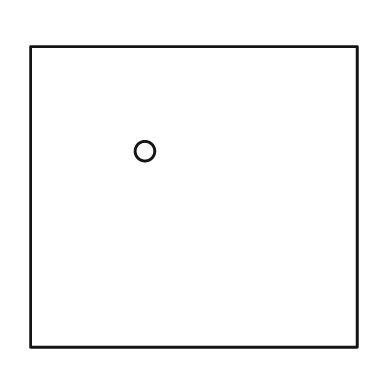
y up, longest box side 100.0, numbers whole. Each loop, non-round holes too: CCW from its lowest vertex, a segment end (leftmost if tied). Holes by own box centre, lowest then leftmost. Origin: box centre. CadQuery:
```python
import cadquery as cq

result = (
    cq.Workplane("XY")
    .moveTo(-50.0, -46.0)
    .lineTo(50.0, -46.0)
    .lineTo(50.0, 46.0)
    .lineTo(-50.0, 46.0)
    .close()
    .moveTo(-15.0, 14.0)
    .circle(3.0)
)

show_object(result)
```